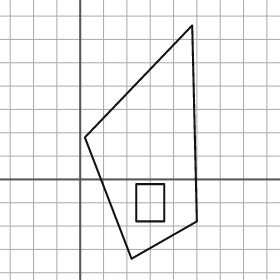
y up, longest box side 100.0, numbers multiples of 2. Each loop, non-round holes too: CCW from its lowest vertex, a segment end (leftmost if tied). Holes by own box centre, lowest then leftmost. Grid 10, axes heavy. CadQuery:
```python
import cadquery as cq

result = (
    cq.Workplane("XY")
    .moveTo(22.0, -34.0)
    .lineTo(50.0, -18.0)
    .lineTo(48.0, 66.0)
    .lineTo(2.0, 18.0)
    .close()
    .moveTo(24.0, -18.0)
    .lineTo(36.0, -18.0)
    .lineTo(36.0, -2.0)
    .lineTo(24.0, -2.0)
    .close()
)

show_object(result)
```